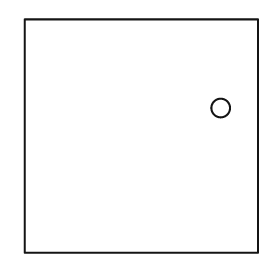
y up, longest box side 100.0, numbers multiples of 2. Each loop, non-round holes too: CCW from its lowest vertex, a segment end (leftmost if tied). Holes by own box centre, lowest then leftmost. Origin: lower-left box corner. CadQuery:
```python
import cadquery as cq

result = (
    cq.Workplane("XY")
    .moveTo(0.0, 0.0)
    .lineTo(100.0, 0.0)
    .lineTo(100.0, 100.0)
    .lineTo(0.0, 100.0)
    .close()
    .moveTo(84.0, 62.0)
    .circle(4.0)
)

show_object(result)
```